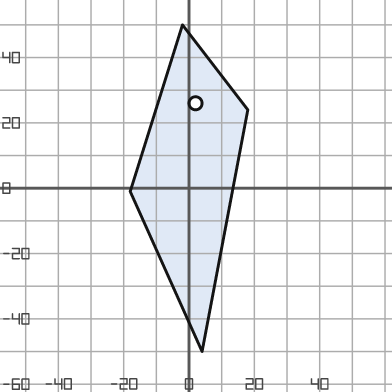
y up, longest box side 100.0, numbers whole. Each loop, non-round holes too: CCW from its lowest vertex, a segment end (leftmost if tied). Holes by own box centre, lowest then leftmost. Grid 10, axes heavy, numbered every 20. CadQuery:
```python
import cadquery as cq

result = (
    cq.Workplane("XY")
    .moveTo(4.0, -50.0)
    .lineTo(18.0, 24.0)
    .lineTo(-2.0, 50.0)
    .lineTo(-18.0, -1.0)
    .close()
    .moveTo(2.0, 26.0)
    .circle(2.0)
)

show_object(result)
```